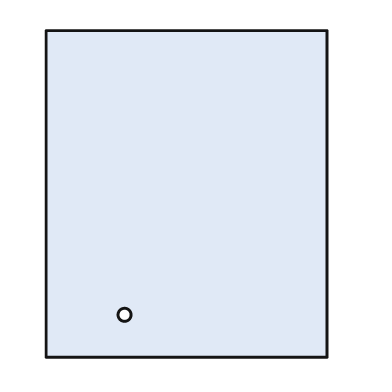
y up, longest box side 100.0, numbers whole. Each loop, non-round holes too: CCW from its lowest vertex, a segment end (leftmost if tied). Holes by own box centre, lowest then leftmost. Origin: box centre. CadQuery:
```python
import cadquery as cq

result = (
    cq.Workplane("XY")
    .moveTo(-43.0, -50.0)
    .lineTo(43.0, -50.0)
    .lineTo(43.0, 50.0)
    .lineTo(-43.0, 50.0)
    .close()
    .moveTo(-19.0, -37.0)
    .circle(2.0)
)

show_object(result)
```